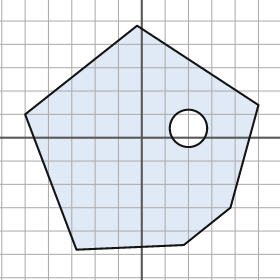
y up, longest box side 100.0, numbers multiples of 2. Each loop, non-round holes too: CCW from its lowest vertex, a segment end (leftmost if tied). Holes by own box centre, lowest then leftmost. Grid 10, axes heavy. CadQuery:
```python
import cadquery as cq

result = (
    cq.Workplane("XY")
    .moveTo(-28.0, -48.0)
    .lineTo(18.0, -46.0)
    .lineTo(38.0, -30.0)
    .lineTo(50.0, 14.0)
    .lineTo(-2.0, 48.0)
    .lineTo(-50.0, 10.0)
    .close()
    .moveTo(20.0, 4.0)
    .circle(8.0)
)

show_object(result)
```